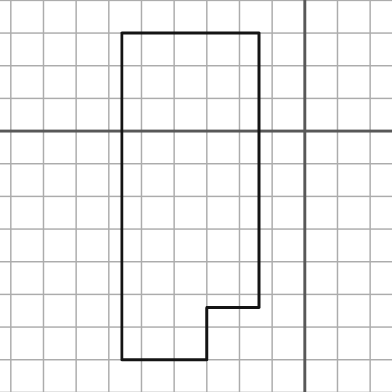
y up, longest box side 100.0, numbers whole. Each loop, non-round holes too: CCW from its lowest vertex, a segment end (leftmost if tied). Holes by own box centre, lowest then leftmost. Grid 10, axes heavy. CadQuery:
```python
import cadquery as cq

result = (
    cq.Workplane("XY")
    .moveTo(-56.0, -70.0)
    .lineTo(-30.0, -70.0)
    .lineTo(-30.0, -54.0)
    .lineTo(-14.0, -54.0)
    .lineTo(-14.0, 30.0)
    .lineTo(-56.0, 30.0)
    .close()
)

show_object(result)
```